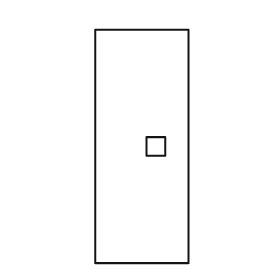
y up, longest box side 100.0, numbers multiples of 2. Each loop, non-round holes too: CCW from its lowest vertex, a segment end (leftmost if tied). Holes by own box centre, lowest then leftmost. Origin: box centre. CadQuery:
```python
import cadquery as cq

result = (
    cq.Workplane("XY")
    .moveTo(-20.0, -50.0)
    .lineTo(20.0, -50.0)
    .lineTo(20.0, 50.0)
    .lineTo(-20.0, 50.0)
    .close()
    .moveTo(2.0, -4.0)
    .lineTo(10.0, -4.0)
    .lineTo(10.0, 4.0)
    .lineTo(2.0, 4.0)
    .close()
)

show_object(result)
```